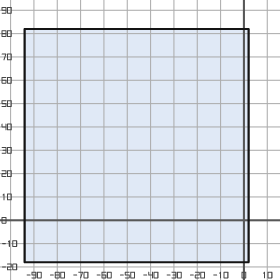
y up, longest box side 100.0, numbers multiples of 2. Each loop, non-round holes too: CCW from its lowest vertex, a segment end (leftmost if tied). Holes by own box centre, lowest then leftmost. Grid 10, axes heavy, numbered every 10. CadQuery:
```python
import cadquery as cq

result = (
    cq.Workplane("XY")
    .moveTo(-94.0, -18.0)
    .lineTo(2.0, -18.0)
    .lineTo(2.0, 82.0)
    .lineTo(-94.0, 82.0)
    .close()
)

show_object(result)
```